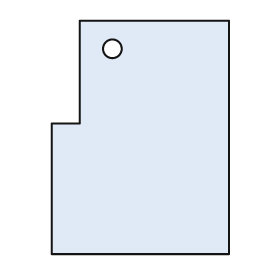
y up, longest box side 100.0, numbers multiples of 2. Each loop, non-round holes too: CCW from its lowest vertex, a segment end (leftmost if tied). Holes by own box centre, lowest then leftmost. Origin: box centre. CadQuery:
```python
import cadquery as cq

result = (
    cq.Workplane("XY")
    .moveTo(-38.0, -50.0)
    .lineTo(38.0, -50.0)
    .lineTo(38.0, 50.0)
    .lineTo(-26.0, 50.0)
    .lineTo(-26.0, 6.0)
    .lineTo(-38.0, 6.0)
    .close()
    .moveTo(-12.0, 38.0)
    .circle(4.0)
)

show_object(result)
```